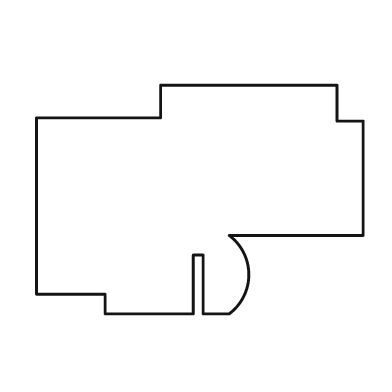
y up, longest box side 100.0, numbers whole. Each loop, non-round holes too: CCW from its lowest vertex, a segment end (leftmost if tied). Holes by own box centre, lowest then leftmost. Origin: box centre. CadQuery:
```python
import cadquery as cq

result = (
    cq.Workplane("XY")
    .moveTo(-29.0, -35.0)
    .lineTo(-2.0, -35.0)
    .lineTo(-2.0, -17.0)
    .lineTo(1.0, -17.0)
    .lineTo(1.0, -35.0)
    .lineTo(9.0, -35.0)
    .threePointArc((15.0, -23.0), (9.0, -11.0))
    .lineTo(50.0, -11.0)
    .lineTo(50.0, 24.0)
    .lineTo(42.0, 24.0)
    .lineTo(42.0, 35.0)
    .lineTo(-12.0, 35.0)
    .lineTo(-12.0, 25.0)
    .lineTo(-50.0, 25.0)
    .lineTo(-50.0, -29.0)
    .lineTo(-29.0, -29.0)
    .close()
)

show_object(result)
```